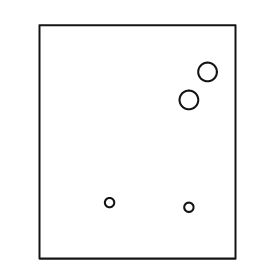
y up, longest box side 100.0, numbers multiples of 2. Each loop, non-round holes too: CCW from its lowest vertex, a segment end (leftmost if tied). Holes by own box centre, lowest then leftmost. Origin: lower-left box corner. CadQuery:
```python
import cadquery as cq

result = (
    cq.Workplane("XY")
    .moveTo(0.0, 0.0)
    .lineTo(84.0, 0.0)
    .lineTo(84.0, 100.0)
    .lineTo(0.0, 100.0)
    .close()
    .moveTo(64.0, 22.0)
    .circle(2.0)
    .moveTo(30.0, 24.0)
    .circle(2.0)
    .moveTo(64.0, 68.0)
    .circle(4.0)
    .moveTo(72.0, 80.0)
    .circle(4.0)
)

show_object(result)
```